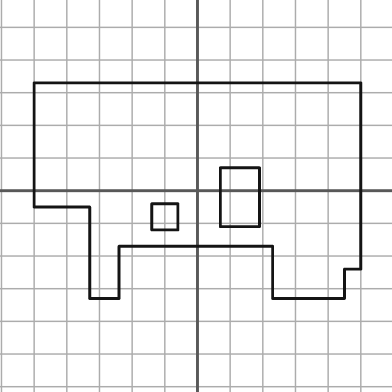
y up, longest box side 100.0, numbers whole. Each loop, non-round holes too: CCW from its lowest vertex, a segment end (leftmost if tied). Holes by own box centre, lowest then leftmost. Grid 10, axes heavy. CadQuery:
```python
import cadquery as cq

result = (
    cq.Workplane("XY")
    .moveTo(-33.0, -33.0)
    .lineTo(-24.0, -33.0)
    .lineTo(-24.0, -17.0)
    .lineTo(23.0, -17.0)
    .lineTo(23.0, -33.0)
    .lineTo(45.0, -33.0)
    .lineTo(45.0, -24.0)
    .lineTo(50.0, -24.0)
    .lineTo(50.0, 33.0)
    .lineTo(-50.0, 33.0)
    .lineTo(-50.0, -5.0)
    .lineTo(-33.0, -5.0)
    .close()
    .moveTo(-14.0, -12.0)
    .lineTo(-6.0, -12.0)
    .lineTo(-6.0, -4.0)
    .lineTo(-14.0, -4.0)
    .close()
    .moveTo(7.0, -11.0)
    .lineTo(19.0, -11.0)
    .lineTo(19.0, 7.0)
    .lineTo(7.0, 7.0)
    .close()
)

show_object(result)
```